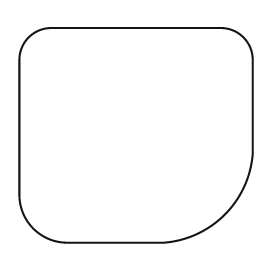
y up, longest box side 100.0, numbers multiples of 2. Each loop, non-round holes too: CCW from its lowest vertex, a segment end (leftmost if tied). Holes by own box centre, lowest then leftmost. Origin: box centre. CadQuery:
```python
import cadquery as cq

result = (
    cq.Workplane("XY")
    .moveTo(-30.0, -46.0)
    .lineTo(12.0, -46.0)
    .threePointArc((38.0, -34.0), (50.0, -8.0))
    .lineTo(50.0, 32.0)
    .threePointArc((46.0, 42.0), (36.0, 46.0))
    .lineTo(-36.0, 46.0)
    .threePointArc((-46.0, 42.0), (-50.0, 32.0))
    .lineTo(-50.0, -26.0)
    .threePointArc((-44.0, -40.0), (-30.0, -46.0))
    .close()
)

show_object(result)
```